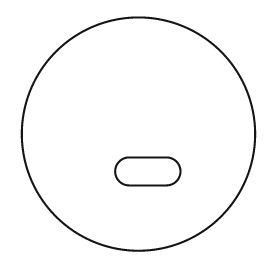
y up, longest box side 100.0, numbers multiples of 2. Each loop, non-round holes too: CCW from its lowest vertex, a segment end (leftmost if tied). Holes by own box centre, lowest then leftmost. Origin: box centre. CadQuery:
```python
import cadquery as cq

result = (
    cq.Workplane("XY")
    .moveTo(0.0, 0.0)
    .circle(50.0)
    .moveTo(-4.0, -22.0)
    .lineTo(12.0, -22.0)
    .threePointArc((18.0, -16.0), (12.0, -10.0))
    .lineTo(-4.0, -10.0)
    .threePointArc((-10.0, -16.0), (-4.0, -22.0))
    .close()
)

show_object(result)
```